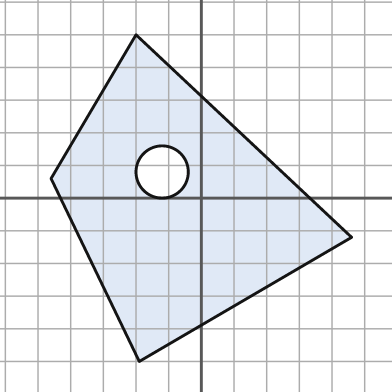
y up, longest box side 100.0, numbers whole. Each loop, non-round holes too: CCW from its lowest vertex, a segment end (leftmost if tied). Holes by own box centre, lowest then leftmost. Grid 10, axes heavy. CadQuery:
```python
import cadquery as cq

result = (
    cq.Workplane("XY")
    .moveTo(-19.0, -50.0)
    .lineTo(46.0, -12.0)
    .lineTo(-20.0, 50.0)
    .lineTo(-46.0, 6.0)
    .close()
    .moveTo(-12.0, 8.0)
    .circle(8.0)
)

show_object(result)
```